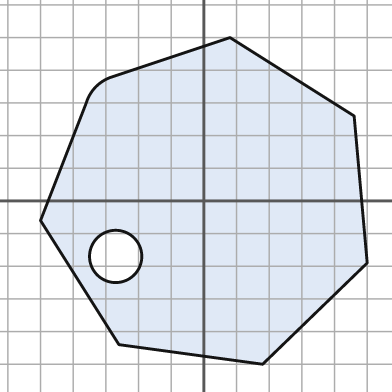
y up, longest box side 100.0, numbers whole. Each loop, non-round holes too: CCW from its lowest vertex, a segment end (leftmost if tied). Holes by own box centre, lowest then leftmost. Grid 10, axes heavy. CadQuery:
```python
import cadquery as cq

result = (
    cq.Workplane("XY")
    .moveTo(18.0, -50.0)
    .lineTo(50.0, -19.0)
    .lineTo(46.0, 26.0)
    .lineTo(8.0, 50.0)
    .lineTo(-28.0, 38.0)
    .threePointArc((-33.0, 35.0), (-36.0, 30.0))
    .lineTo(-50.0, -6.0)
    .lineTo(-26.0, -44.0)
    .close()
    .moveTo(-27.0, -17.0)
    .circle(8.0)
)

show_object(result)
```